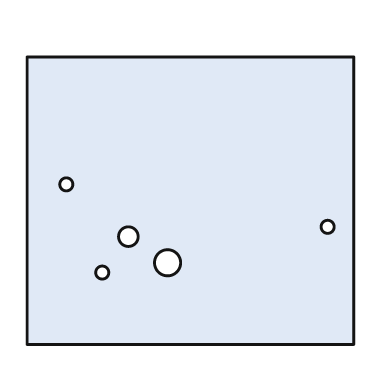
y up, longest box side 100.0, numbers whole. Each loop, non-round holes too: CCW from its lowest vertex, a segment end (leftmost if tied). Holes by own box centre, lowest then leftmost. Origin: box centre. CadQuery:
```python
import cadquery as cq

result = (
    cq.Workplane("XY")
    .moveTo(-50.0, -44.0)
    .lineTo(50.0, -44.0)
    .lineTo(50.0, 44.0)
    .lineTo(-50.0, 44.0)
    .close()
    .moveTo(-27.0, -22.0)
    .circle(2.0)
    .moveTo(-7.0, -19.0)
    .circle(4.0)
    .moveTo(-19.0, -11.0)
    .circle(3.0)
    .moveTo(42.0, -8.0)
    .circle(2.0)
    .moveTo(-38.0, 5.0)
    .circle(2.0)
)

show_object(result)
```